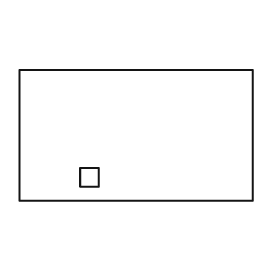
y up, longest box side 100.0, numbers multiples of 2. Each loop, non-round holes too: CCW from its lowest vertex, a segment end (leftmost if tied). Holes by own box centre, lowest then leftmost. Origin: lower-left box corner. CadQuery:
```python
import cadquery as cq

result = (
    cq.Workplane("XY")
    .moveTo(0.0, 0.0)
    .lineTo(100.0, 0.0)
    .lineTo(100.0, 56.0)
    .lineTo(0.0, 56.0)
    .close()
    .moveTo(26.0, 6.0)
    .lineTo(34.0, 6.0)
    .lineTo(34.0, 14.0)
    .lineTo(26.0, 14.0)
    .close()
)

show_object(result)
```